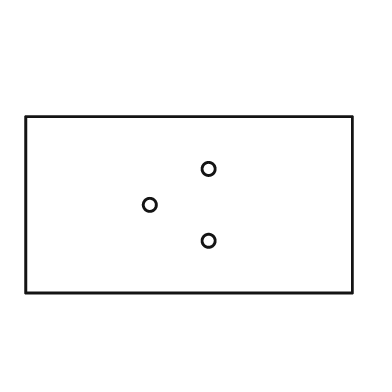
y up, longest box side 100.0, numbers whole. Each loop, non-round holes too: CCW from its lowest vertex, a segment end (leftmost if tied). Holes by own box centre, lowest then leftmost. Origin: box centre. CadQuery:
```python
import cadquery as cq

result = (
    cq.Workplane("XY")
    .moveTo(-50.0, -27.0)
    .lineTo(50.0, -27.0)
    .lineTo(50.0, 27.0)
    .lineTo(-50.0, 27.0)
    .close()
    .moveTo(6.0, -11.0)
    .circle(2.0)
    .moveTo(-12.0, 0.0)
    .circle(2.0)
    .moveTo(6.0, 11.0)
    .circle(2.0)
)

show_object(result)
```